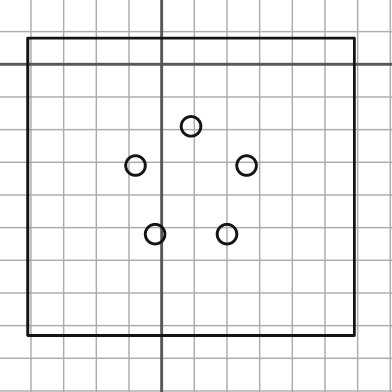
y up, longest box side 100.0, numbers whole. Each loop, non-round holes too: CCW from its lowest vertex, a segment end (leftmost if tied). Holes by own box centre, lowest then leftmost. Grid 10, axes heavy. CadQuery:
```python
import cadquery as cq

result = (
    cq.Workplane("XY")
    .moveTo(-41.0, -83.0)
    .lineTo(59.0, -83.0)
    .lineTo(59.0, 8.0)
    .lineTo(-41.0, 8.0)
    .close()
    .moveTo(-2.0, -52.0)
    .circle(3.0)
    .moveTo(20.0, -52.0)
    .circle(3.0)
    .moveTo(-8.0, -31.0)
    .circle(3.0)
    .moveTo(26.0, -31.0)
    .circle(3.0)
    .moveTo(9.0, -19.0)
    .circle(3.0)
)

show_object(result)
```